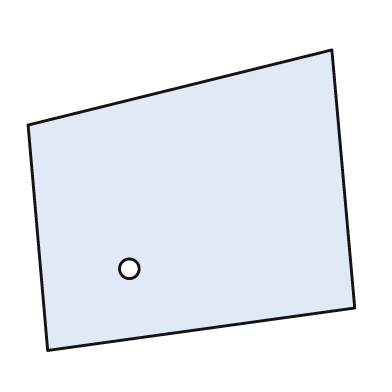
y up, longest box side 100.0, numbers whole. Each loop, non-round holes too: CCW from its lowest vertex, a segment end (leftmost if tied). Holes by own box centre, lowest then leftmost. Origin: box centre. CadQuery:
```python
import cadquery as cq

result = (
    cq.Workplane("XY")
    .moveTo(-44.0, -46.0)
    .lineTo(50.0, -33.0)
    .lineTo(43.0, 46.0)
    .lineTo(-50.0, 23.0)
    .close()
    .moveTo(-19.0, -21.0)
    .circle(3.0)
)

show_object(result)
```